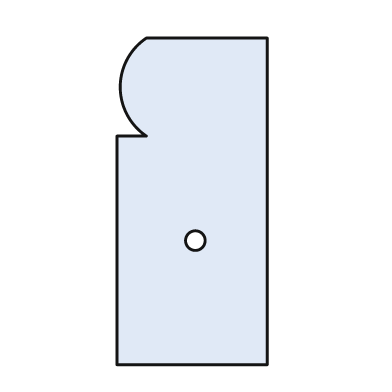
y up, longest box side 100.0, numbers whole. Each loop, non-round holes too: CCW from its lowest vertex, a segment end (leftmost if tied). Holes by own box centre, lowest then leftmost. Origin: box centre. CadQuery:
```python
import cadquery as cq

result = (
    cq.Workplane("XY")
    .moveTo(-23.0, -50.0)
    .lineTo(23.0, -50.0)
    .lineTo(23.0, 50.0)
    .lineTo(-14.0, 50.0)
    .threePointArc((-22.0, 35.0), (-14.0, 20.0))
    .lineTo(-23.0, 20.0)
    .close()
    .moveTo(1.0, -12.0)
    .circle(3.0)
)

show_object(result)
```